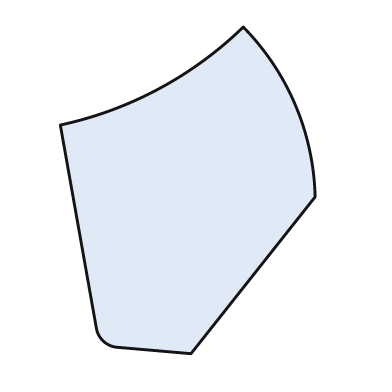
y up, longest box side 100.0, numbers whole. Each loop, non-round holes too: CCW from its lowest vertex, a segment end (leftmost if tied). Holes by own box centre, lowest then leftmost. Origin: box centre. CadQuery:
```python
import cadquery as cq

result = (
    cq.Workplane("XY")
    .moveTo(1.0, -50.0)
    .lineTo(39.0, -2.0)
    .threePointArc((33.0, 26.0), (17.0, 50.0))
    .threePointArc((-9.0, 31.0), (-39.0, 20.0))
    .lineTo(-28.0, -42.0)
    .threePointArc((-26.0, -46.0), (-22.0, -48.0))
    .close()
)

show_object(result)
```